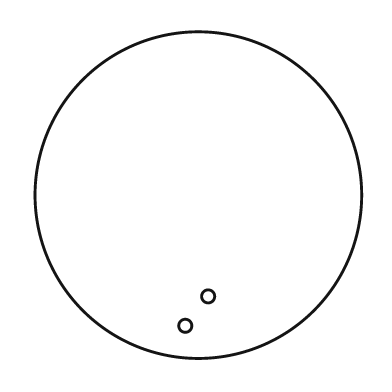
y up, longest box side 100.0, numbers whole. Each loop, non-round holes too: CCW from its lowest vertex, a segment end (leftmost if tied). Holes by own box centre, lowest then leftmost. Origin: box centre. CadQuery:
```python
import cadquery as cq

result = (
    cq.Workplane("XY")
    .moveTo(0.0, 0.0)
    .circle(50.0)
    .moveTo(-4.0, -40.0)
    .circle(2.0)
    .moveTo(3.0, -31.0)
    .circle(2.0)
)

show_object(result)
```